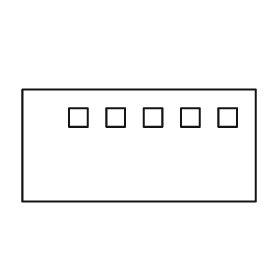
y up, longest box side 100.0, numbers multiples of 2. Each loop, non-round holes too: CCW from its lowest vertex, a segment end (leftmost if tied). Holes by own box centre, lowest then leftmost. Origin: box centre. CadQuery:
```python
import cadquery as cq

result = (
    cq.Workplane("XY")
    .moveTo(-50.0, -24.0)
    .lineTo(50.0, -24.0)
    .lineTo(50.0, 24.0)
    .lineTo(-50.0, 24.0)
    .close()
    .moveTo(-30.0, 8.0)
    .lineTo(-22.0, 8.0)
    .lineTo(-22.0, 16.0)
    .lineTo(-30.0, 16.0)
    .close()
    .moveTo(-14.0, 8.0)
    .lineTo(-6.0, 8.0)
    .lineTo(-6.0, 16.0)
    .lineTo(-14.0, 16.0)
    .close()
    .moveTo(2.0, 8.0)
    .lineTo(10.0, 8.0)
    .lineTo(10.0, 16.0)
    .lineTo(2.0, 16.0)
    .close()
    .moveTo(18.0, 8.0)
    .lineTo(26.0, 8.0)
    .lineTo(26.0, 16.0)
    .lineTo(18.0, 16.0)
    .close()
    .moveTo(34.0, 8.0)
    .lineTo(42.0, 8.0)
    .lineTo(42.0, 16.0)
    .lineTo(34.0, 16.0)
    .close()
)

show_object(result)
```